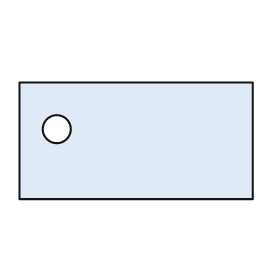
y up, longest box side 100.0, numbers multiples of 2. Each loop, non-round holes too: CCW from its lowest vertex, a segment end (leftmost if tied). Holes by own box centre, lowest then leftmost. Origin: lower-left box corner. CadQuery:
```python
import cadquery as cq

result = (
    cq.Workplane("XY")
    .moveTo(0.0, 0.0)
    .lineTo(100.0, 0.0)
    .lineTo(100.0, 50.0)
    .lineTo(0.0, 50.0)
    .close()
    .moveTo(16.0, 30.0)
    .circle(6.0)
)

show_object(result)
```